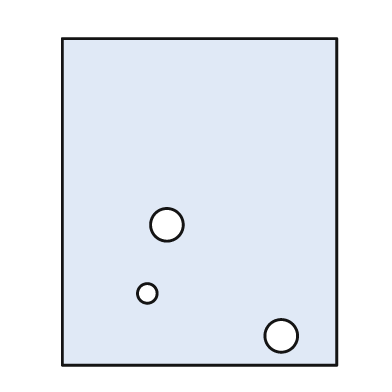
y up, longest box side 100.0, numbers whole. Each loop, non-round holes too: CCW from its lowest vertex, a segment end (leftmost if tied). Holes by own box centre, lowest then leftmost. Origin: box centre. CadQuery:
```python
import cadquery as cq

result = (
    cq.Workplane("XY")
    .moveTo(-42.0, -50.0)
    .lineTo(42.0, -50.0)
    .lineTo(42.0, 50.0)
    .lineTo(-42.0, 50.0)
    .close()
    .moveTo(25.0, -41.0)
    .circle(5.0)
    .moveTo(-16.0, -28.0)
    .circle(3.0)
    .moveTo(-10.0, -7.0)
    .circle(5.0)
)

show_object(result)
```